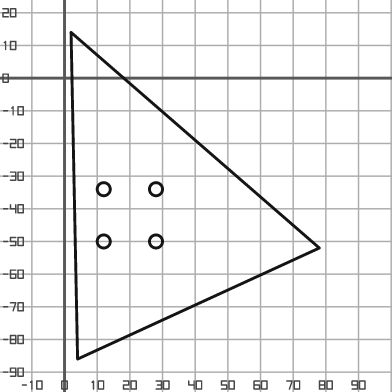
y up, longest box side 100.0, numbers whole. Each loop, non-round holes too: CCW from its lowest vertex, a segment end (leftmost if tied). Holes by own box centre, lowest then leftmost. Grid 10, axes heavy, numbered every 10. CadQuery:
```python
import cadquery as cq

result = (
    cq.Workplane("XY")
    .moveTo(4.0, -86.0)
    .lineTo(78.0, -52.0)
    .lineTo(2.0, 14.0)
    .close()
    .moveTo(12.0, -50.0)
    .circle(2.0)
    .moveTo(28.0, -50.0)
    .circle(2.0)
    .moveTo(12.0, -34.0)
    .circle(2.0)
    .moveTo(28.0, -34.0)
    .circle(2.0)
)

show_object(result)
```